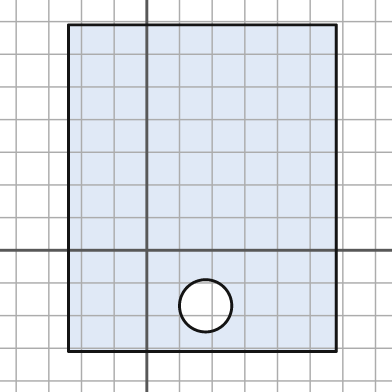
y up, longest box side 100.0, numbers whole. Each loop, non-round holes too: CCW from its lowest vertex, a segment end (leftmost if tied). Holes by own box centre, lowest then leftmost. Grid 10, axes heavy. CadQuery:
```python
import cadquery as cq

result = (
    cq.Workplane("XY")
    .moveTo(-24.0, -31.0)
    .lineTo(58.0, -31.0)
    .lineTo(58.0, 69.0)
    .lineTo(-24.0, 69.0)
    .close()
    .moveTo(18.0, -17.0)
    .circle(8.0)
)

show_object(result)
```